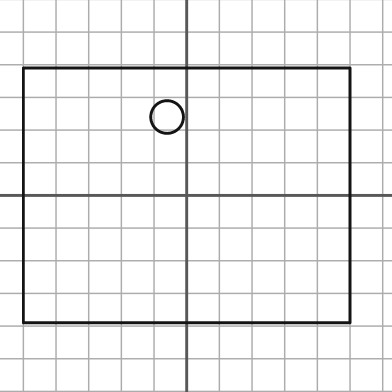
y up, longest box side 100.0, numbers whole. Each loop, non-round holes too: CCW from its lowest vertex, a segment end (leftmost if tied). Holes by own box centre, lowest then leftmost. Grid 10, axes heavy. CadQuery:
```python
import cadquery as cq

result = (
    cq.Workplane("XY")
    .moveTo(-50.0, -39.0)
    .lineTo(50.0, -39.0)
    .lineTo(50.0, 39.0)
    .lineTo(-50.0, 39.0)
    .close()
    .moveTo(-6.0, 24.0)
    .circle(5.0)
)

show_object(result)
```